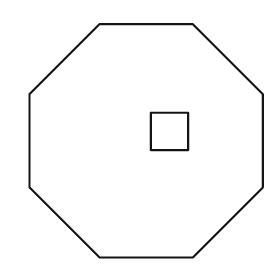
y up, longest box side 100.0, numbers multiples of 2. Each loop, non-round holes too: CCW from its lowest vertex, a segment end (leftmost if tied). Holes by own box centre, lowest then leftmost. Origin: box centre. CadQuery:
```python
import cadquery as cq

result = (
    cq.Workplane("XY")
    .moveTo(-20.0, -50.0)
    .lineTo(20.0, -50.0)
    .lineTo(50.0, -20.0)
    .lineTo(50.0, 20.0)
    .lineTo(20.0, 50.0)
    .lineTo(-20.0, 50.0)
    .lineTo(-50.0, 20.0)
    .lineTo(-50.0, -20.0)
    .close()
    .moveTo(2.0, -4.0)
    .lineTo(18.0, -4.0)
    .lineTo(18.0, 12.0)
    .lineTo(2.0, 12.0)
    .close()
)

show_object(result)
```